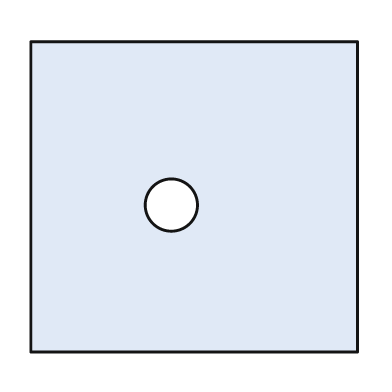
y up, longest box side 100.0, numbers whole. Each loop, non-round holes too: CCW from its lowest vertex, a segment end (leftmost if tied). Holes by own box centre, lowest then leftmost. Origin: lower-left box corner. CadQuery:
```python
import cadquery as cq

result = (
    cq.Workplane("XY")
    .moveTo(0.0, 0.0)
    .lineTo(100.0, 0.0)
    .lineTo(100.0, 95.0)
    .lineTo(0.0, 95.0)
    .close()
    .moveTo(43.0, 45.0)
    .circle(8.0)
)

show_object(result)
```